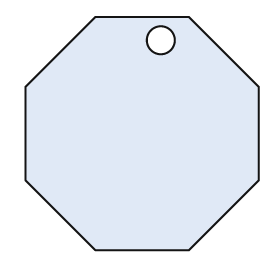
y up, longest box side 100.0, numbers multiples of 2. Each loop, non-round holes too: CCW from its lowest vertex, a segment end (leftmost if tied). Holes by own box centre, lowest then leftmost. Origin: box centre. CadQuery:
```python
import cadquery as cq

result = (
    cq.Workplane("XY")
    .moveTo(-20.0, -50.0)
    .lineTo(20.0, -50.0)
    .lineTo(50.0, -20.0)
    .lineTo(50.0, 20.0)
    .lineTo(20.0, 50.0)
    .lineTo(-20.0, 50.0)
    .lineTo(-50.0, 20.0)
    .lineTo(-50.0, -20.0)
    .close()
    .moveTo(8.0, 40.0)
    .circle(6.0)
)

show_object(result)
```